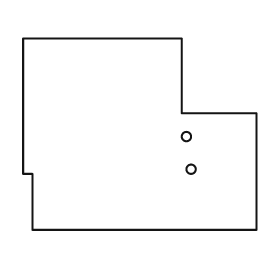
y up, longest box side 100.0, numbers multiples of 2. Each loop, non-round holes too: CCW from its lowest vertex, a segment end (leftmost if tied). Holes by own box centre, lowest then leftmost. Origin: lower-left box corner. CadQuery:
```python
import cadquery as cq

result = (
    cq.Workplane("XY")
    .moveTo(4.0, 0.0)
    .lineTo(100.0, 0.0)
    .lineTo(100.0, 50.0)
    .lineTo(68.0, 50.0)
    .lineTo(68.0, 82.0)
    .lineTo(0.0, 82.0)
    .lineTo(0.0, 24.0)
    .lineTo(4.0, 24.0)
    .close()
    .moveTo(72.0, 26.0)
    .circle(2.0)
    .moveTo(70.0, 40.0)
    .circle(2.0)
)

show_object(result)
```